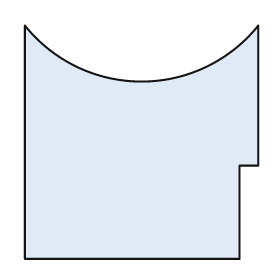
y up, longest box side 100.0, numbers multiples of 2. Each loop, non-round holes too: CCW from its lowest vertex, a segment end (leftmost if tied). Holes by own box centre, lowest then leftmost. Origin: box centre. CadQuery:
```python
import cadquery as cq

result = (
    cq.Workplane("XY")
    .moveTo(-50.0, -50.0)
    .lineTo(42.0, -50.0)
    .lineTo(42.0, -10.0)
    .lineTo(50.0, -10.0)
    .lineTo(50.0, 50.0)
    .threePointArc((0.0, 26.0), (-50.0, 50.0))
    .close()
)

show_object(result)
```